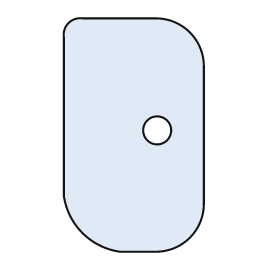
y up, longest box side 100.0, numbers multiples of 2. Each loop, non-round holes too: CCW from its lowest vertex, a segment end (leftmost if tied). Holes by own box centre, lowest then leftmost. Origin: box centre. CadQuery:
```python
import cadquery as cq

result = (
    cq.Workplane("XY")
    .moveTo(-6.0, -50.0)
    .lineTo(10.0, -50.0)
    .threePointArc((24.0, -44.0), (30.0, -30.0))
    .lineTo(30.0, 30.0)
    .threePointArc((24.0, 44.0), (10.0, 50.0))
    .lineTo(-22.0, 50.0)
    .threePointArc((-28.0, 48.0), (-30.0, 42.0))
    .lineTo(-30.0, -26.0)
    .threePointArc((-22.0, -42.0), (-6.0, -50.0))
    .close()
    .moveTo(10.0, 2.0)
    .circle(6.0)
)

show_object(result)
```